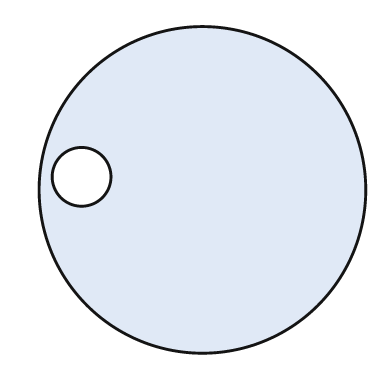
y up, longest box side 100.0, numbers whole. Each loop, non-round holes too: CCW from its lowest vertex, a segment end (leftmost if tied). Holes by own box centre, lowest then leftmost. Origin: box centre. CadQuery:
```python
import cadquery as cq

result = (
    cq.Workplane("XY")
    .moveTo(0.0, 0.0)
    .circle(50.0)
    .moveTo(-37.0, 4.0)
    .circle(9.0)
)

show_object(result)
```